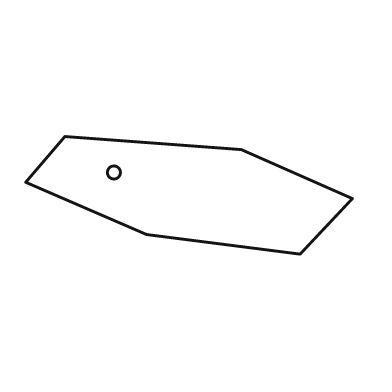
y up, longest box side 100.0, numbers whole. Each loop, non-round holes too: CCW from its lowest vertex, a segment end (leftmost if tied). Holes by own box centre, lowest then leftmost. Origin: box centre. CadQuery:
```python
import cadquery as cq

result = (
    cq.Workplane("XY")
    .moveTo(34.0, -18.0)
    .lineTo(50.0, -1.0)
    .lineTo(16.0, 14.0)
    .lineTo(-38.0, 18.0)
    .lineTo(-50.0, 4.0)
    .lineTo(-13.0, -12.0)
    .close()
    .moveTo(-23.0, 7.0)
    .circle(2.0)
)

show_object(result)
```